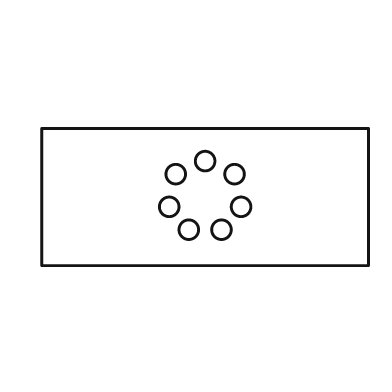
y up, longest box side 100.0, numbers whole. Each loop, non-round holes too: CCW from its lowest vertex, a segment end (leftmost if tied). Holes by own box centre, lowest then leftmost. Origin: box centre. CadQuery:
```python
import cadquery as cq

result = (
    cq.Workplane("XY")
    .moveTo(-50.0, -21.0)
    .lineTo(50.0, -21.0)
    .lineTo(50.0, 21.0)
    .lineTo(-50.0, 21.0)
    .close()
    .moveTo(-5.0, -10.0)
    .circle(3.0)
    .moveTo(5.0, -10.0)
    .circle(3.0)
    .moveTo(-11.0, -3.0)
    .circle(3.0)
    .moveTo(11.0, -3.0)
    .circle(3.0)
    .moveTo(-9.0, 7.0)
    .circle(3.0)
    .moveTo(9.0, 7.0)
    .circle(3.0)
    .moveTo(0.0, 11.0)
    .circle(3.0)
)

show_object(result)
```